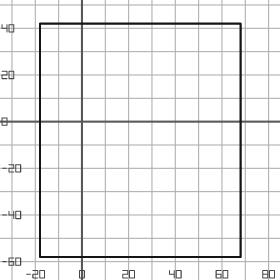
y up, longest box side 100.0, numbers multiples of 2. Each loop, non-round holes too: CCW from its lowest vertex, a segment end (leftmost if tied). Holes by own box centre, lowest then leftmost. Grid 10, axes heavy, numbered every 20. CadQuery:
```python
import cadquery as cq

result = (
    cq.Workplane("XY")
    .moveTo(-18.0, -58.0)
    .lineTo(68.0, -58.0)
    .lineTo(68.0, 42.0)
    .lineTo(-18.0, 42.0)
    .close()
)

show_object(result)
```